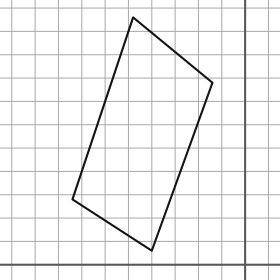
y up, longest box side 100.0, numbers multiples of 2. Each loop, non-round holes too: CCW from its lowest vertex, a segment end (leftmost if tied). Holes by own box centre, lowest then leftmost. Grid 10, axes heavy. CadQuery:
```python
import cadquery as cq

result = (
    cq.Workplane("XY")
    .moveTo(-40.0, 6.0)
    .lineTo(-14.0, 78.0)
    .lineTo(-48.0, 106.0)
    .lineTo(-74.0, 28.0)
    .close()
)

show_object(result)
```